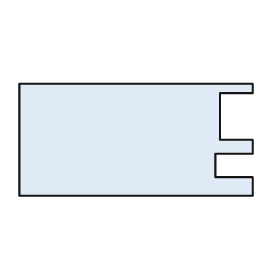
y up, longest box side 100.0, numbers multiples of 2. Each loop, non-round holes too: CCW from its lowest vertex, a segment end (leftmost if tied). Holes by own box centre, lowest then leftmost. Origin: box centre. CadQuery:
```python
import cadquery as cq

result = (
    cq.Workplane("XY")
    .moveTo(-50.0, -24.0)
    .lineTo(50.0, -24.0)
    .lineTo(50.0, -16.0)
    .lineTo(34.0, -16.0)
    .lineTo(34.0, -6.0)
    .lineTo(50.0, -6.0)
    .lineTo(50.0, 0.0)
    .lineTo(36.0, 0.0)
    .lineTo(36.0, 20.0)
    .lineTo(50.0, 20.0)
    .lineTo(50.0, 24.0)
    .lineTo(-50.0, 24.0)
    .close()
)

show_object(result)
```